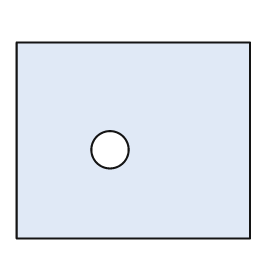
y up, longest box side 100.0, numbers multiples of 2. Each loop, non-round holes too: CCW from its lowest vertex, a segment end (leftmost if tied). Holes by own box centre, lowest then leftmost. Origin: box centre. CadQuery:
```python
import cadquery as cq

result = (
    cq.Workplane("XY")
    .moveTo(-50.0, -42.0)
    .lineTo(50.0, -42.0)
    .lineTo(50.0, 42.0)
    .lineTo(-50.0, 42.0)
    .close()
    .moveTo(-10.0, -4.0)
    .circle(8.0)
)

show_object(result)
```